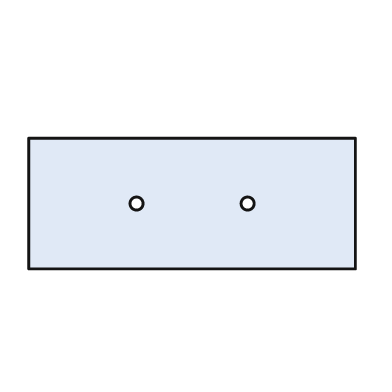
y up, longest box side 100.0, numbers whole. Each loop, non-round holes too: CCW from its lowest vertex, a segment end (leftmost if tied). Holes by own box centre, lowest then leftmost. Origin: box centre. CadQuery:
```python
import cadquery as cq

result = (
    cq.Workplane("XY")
    .moveTo(-50.0, -20.0)
    .lineTo(50.0, -20.0)
    .lineTo(50.0, 20.0)
    .lineTo(-50.0, 20.0)
    .close()
    .moveTo(-17.0, 0.0)
    .circle(2.0)
    .moveTo(17.0, 0.0)
    .circle(2.0)
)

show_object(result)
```